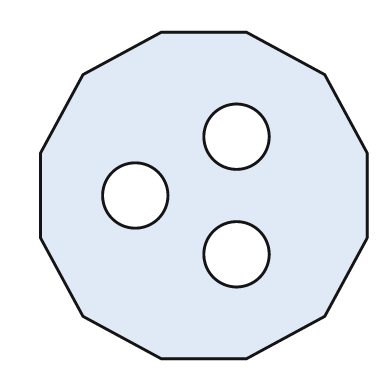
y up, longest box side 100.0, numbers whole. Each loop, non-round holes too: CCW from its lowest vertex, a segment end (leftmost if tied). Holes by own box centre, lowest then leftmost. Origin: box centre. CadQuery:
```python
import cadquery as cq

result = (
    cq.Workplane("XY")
    .moveTo(-13.0, -50.0)
    .lineTo(13.0, -50.0)
    .lineTo(37.0, -37.0)
    .lineTo(50.0, -13.0)
    .lineTo(50.0, 13.0)
    .lineTo(37.0, 37.0)
    .lineTo(13.0, 50.0)
    .lineTo(-13.0, 50.0)
    .lineTo(-37.0, 37.0)
    .lineTo(-50.0, 13.0)
    .lineTo(-50.0, -13.0)
    .lineTo(-37.0, -37.0)
    .close()
    .moveTo(10.0, -18.0)
    .circle(10.0)
    .moveTo(-21.0, 0.0)
    .circle(10.0)
    .moveTo(10.0, 18.0)
    .circle(10.0)
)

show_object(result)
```